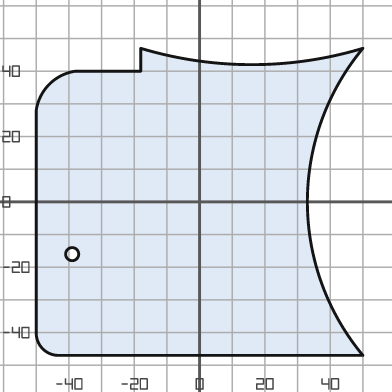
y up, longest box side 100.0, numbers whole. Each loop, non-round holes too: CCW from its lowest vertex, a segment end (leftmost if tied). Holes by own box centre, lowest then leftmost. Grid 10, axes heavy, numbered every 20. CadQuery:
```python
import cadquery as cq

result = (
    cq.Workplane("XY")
    .moveTo(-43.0, -47.0)
    .lineTo(50.0, -47.0)
    .threePointArc((33.0, 0.0), (50.0, 47.0))
    .threePointArc((16.0, 42.0), (-18.0, 47.0))
    .lineTo(-18.0, 40.0)
    .lineTo(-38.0, 40.0)
    .threePointArc((-46.0, 36.0), (-50.0, 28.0))
    .lineTo(-50.0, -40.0)
    .threePointArc((-48.0, -45.0), (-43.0, -47.0))
    .close()
    .moveTo(-39.0, -16.0)
    .circle(2.0)
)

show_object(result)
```